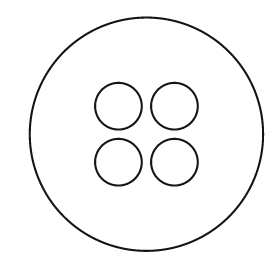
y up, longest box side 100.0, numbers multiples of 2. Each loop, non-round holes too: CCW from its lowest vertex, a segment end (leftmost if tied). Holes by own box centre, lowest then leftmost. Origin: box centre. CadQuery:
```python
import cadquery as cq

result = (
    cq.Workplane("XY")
    .moveTo(0.0, 0.0)
    .circle(50.0)
    .moveTo(-12.0, -12.0)
    .circle(10.0)
    .moveTo(12.0, -12.0)
    .circle(10.0)
    .moveTo(-12.0, 12.0)
    .circle(10.0)
    .moveTo(12.0, 12.0)
    .circle(10.0)
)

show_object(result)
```